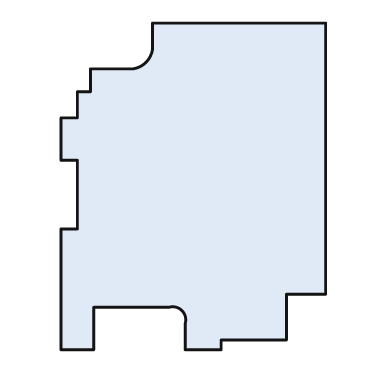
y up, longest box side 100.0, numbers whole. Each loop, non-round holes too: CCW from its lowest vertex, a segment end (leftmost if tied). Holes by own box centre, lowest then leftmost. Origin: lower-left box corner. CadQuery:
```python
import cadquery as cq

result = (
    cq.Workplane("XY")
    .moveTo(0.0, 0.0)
    .lineTo(10.0, 0.0)
    .lineTo(10.0, 13.0)
    .lineTo(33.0, 13.0)
    .threePointArc((37.0, 12.0), (38.0, 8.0))
    .lineTo(38.0, 0.0)
    .lineTo(49.0, 0.0)
    .lineTo(49.0, 3.0)
    .lineTo(69.0, 3.0)
    .lineTo(69.0, 17.0)
    .lineTo(81.0, 17.0)
    .lineTo(81.0, 100.0)
    .lineTo(28.0, 100.0)
    .lineTo(28.0, 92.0)
    .threePointArc((26.0, 88.0), (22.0, 86.0))
    .lineTo(9.0, 86.0)
    .lineTo(9.0, 79.0)
    .lineTo(5.0, 79.0)
    .lineTo(5.0, 71.0)
    .lineTo(0.0, 71.0)
    .lineTo(0.0, 58.0)
    .lineTo(5.0, 58.0)
    .lineTo(5.0, 37.0)
    .lineTo(0.0, 37.0)
    .close()
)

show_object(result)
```